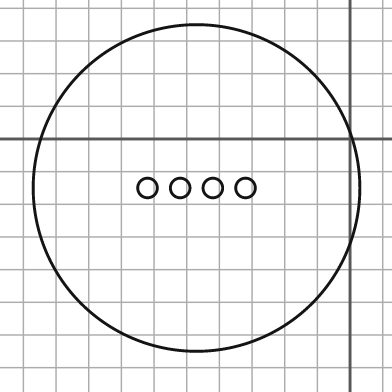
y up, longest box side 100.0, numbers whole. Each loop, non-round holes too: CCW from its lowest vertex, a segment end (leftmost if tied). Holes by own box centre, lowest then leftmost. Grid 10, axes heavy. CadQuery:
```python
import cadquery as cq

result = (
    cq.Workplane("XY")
    .moveTo(-47.0, -15.0)
    .circle(50.0)
    .moveTo(-62.0, -15.0)
    .circle(3.0)
    .moveTo(-52.0, -15.0)
    .circle(3.0)
    .moveTo(-42.0, -15.0)
    .circle(3.0)
    .moveTo(-32.0, -15.0)
    .circle(3.0)
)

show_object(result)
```